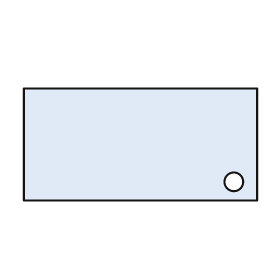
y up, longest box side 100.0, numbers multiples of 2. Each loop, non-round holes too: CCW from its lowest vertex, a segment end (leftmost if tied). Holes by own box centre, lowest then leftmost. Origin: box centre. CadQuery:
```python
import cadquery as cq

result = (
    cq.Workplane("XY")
    .moveTo(-50.0, -24.0)
    .lineTo(50.0, -24.0)
    .lineTo(50.0, 24.0)
    .lineTo(-50.0, 24.0)
    .close()
    .moveTo(40.0, -16.0)
    .circle(4.0)
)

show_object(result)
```